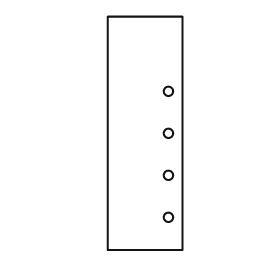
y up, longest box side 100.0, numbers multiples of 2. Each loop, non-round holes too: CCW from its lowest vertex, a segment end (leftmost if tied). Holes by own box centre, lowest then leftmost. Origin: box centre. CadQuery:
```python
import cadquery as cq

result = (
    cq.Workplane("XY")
    .moveTo(-16.0, -50.0)
    .lineTo(16.0, -50.0)
    .lineTo(16.0, 50.0)
    .lineTo(-16.0, 50.0)
    .close()
    .moveTo(10.0, -36.0)
    .circle(2.0)
    .moveTo(10.0, -18.0)
    .circle(2.0)
    .moveTo(10.0, 0.0)
    .circle(2.0)
    .moveTo(10.0, 18.0)
    .circle(2.0)
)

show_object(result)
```